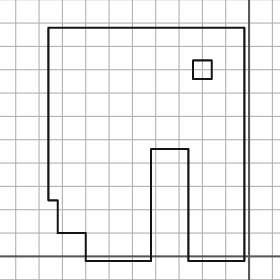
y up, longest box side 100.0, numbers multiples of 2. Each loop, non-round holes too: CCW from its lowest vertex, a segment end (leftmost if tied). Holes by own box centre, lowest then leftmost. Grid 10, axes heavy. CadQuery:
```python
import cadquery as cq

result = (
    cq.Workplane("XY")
    .moveTo(-70.0, -2.0)
    .lineTo(-42.0, -2.0)
    .lineTo(-42.0, 46.0)
    .lineTo(-26.0, 46.0)
    .lineTo(-26.0, -2.0)
    .lineTo(-2.0, -2.0)
    .lineTo(-2.0, 98.0)
    .lineTo(-86.0, 98.0)
    .lineTo(-86.0, 24.0)
    .lineTo(-82.0, 24.0)
    .lineTo(-82.0, 10.0)
    .lineTo(-70.0, 10.0)
    .close()
    .moveTo(-24.0, 76.0)
    .lineTo(-16.0, 76.0)
    .lineTo(-16.0, 84.0)
    .lineTo(-24.0, 84.0)
    .close()
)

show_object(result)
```